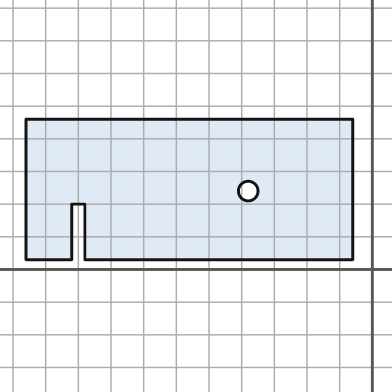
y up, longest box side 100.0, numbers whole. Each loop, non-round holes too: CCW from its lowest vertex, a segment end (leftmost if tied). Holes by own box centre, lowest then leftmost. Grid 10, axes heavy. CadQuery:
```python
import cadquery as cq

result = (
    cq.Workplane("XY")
    .moveTo(-106.0, 3.0)
    .lineTo(-92.0, 3.0)
    .lineTo(-92.0, 20.0)
    .lineTo(-88.0, 20.0)
    .lineTo(-88.0, 3.0)
    .lineTo(-6.0, 3.0)
    .lineTo(-6.0, 46.0)
    .lineTo(-106.0, 46.0)
    .close()
    .moveTo(-38.0, 24.0)
    .circle(3.0)
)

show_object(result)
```